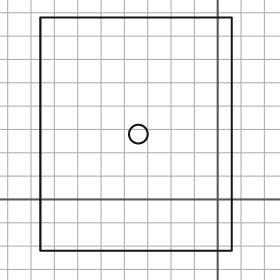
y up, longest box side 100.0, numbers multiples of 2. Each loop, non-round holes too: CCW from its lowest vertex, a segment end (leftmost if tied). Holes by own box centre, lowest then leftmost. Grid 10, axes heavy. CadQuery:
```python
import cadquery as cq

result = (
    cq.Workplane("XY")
    .moveTo(-76.0, -22.0)
    .lineTo(6.0, -22.0)
    .lineTo(6.0, 78.0)
    .lineTo(-76.0, 78.0)
    .close()
    .moveTo(-34.0, 28.0)
    .circle(4.0)
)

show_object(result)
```